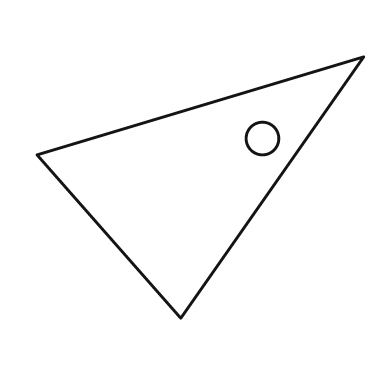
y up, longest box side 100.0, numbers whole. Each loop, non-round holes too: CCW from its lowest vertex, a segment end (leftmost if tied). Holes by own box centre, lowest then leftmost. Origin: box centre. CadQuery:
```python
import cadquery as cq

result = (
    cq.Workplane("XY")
    .moveTo(-6.0, -40.0)
    .lineTo(50.0, 40.0)
    .lineTo(-50.0, 10.0)
    .close()
    .moveTo(19.0, 15.0)
    .circle(5.0)
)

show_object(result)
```